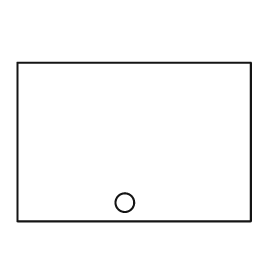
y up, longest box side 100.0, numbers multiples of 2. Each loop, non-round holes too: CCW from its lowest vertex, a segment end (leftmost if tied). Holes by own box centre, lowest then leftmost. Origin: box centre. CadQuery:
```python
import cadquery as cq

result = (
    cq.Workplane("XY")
    .moveTo(-50.0, -34.0)
    .lineTo(50.0, -34.0)
    .lineTo(50.0, 34.0)
    .lineTo(-50.0, 34.0)
    .close()
    .moveTo(-4.0, -26.0)
    .circle(4.0)
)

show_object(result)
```